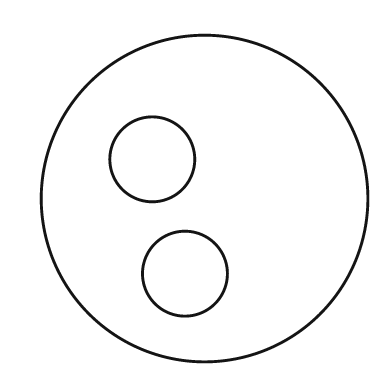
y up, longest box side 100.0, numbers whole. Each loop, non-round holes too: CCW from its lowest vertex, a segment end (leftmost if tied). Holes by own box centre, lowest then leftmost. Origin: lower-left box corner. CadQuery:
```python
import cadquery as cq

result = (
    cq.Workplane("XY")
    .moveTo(50.0, 50.0)
    .circle(50.0)
    .moveTo(44.0, 27.0)
    .circle(13.0)
    .moveTo(34.0, 62.0)
    .circle(13.0)
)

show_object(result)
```